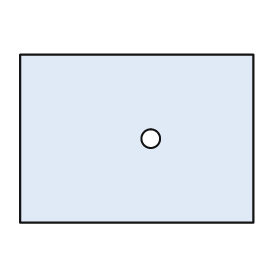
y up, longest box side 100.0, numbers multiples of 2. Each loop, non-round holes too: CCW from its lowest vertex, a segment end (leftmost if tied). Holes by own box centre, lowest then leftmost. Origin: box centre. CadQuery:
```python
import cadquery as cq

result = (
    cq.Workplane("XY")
    .moveTo(-50.0, -36.0)
    .lineTo(50.0, -36.0)
    .lineTo(50.0, 36.0)
    .lineTo(-50.0, 36.0)
    .close()
    .moveTo(6.0, 0.0)
    .circle(4.0)
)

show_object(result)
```